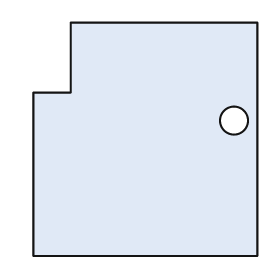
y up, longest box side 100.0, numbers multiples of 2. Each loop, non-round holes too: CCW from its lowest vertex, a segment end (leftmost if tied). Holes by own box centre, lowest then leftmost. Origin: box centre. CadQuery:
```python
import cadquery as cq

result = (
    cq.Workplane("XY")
    .moveTo(-48.0, -50.0)
    .lineTo(48.0, -50.0)
    .lineTo(48.0, 50.0)
    .lineTo(-32.0, 50.0)
    .lineTo(-32.0, 20.0)
    .lineTo(-48.0, 20.0)
    .close()
    .moveTo(38.0, 8.0)
    .circle(6.0)
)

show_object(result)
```